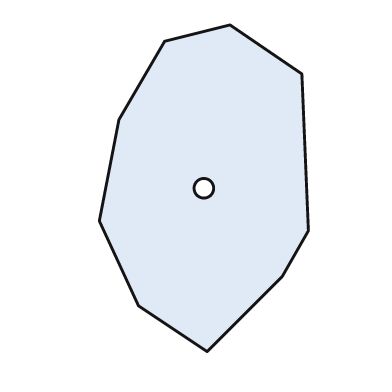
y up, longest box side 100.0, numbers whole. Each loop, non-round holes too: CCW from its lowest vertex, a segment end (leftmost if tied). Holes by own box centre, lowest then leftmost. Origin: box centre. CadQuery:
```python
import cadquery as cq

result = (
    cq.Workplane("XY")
    .moveTo(1.0, -50.0)
    .lineTo(24.0, -27.0)
    .lineTo(32.0, -13.0)
    .lineTo(30.0, 35.0)
    .lineTo(8.0, 50.0)
    .lineTo(-12.0, 45.0)
    .lineTo(-26.0, 21.0)
    .lineTo(-32.0, -10.0)
    .lineTo(-20.0, -36.0)
    .close()
    .moveTo(0.0, 0.0)
    .circle(3.0)
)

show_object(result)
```